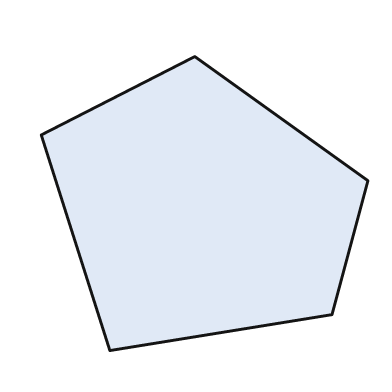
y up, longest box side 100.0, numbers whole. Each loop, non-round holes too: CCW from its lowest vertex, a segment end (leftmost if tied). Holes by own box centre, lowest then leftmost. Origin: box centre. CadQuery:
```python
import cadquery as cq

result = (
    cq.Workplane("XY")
    .moveTo(-29.0, -45.0)
    .lineTo(39.0, -34.0)
    .lineTo(50.0, 7.0)
    .lineTo(-3.0, 45.0)
    .lineTo(-50.0, 21.0)
    .close()
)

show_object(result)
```